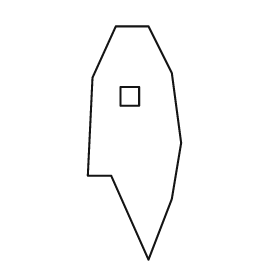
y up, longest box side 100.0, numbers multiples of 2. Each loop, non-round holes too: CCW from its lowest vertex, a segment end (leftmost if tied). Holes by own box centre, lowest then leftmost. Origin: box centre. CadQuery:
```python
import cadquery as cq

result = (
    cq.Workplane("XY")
    .moveTo(6.0, -50.0)
    .lineTo(16.0, -24.0)
    .lineTo(20.0, 0.0)
    .lineTo(16.0, 30.0)
    .lineTo(6.0, 50.0)
    .lineTo(-8.0, 50.0)
    .lineTo(-18.0, 28.0)
    .lineTo(-20.0, -14.0)
    .lineTo(-10.0, -14.0)
    .close()
    .moveTo(-6.0, 16.0)
    .lineTo(2.0, 16.0)
    .lineTo(2.0, 24.0)
    .lineTo(-6.0, 24.0)
    .close()
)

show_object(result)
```